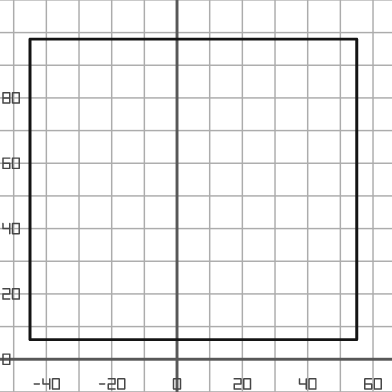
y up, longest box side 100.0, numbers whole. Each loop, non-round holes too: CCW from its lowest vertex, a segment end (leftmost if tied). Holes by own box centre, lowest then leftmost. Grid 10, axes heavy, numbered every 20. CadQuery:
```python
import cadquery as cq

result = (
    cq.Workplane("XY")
    .moveTo(-45.0, 6.0)
    .lineTo(55.0, 6.0)
    .lineTo(55.0, 98.0)
    .lineTo(-45.0, 98.0)
    .close()
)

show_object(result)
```